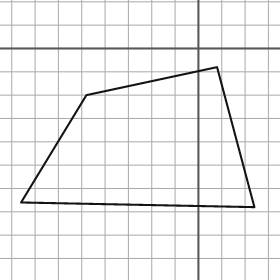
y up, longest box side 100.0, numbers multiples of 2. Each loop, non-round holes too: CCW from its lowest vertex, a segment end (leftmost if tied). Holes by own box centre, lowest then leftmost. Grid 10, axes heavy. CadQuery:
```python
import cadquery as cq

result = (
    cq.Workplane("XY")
    .moveTo(24.0, -68.0)
    .lineTo(8.0, -8.0)
    .lineTo(-48.0, -20.0)
    .lineTo(-76.0, -66.0)
    .close()
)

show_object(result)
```